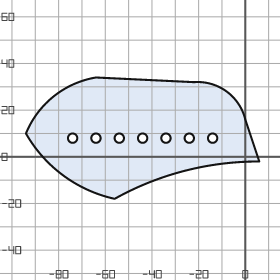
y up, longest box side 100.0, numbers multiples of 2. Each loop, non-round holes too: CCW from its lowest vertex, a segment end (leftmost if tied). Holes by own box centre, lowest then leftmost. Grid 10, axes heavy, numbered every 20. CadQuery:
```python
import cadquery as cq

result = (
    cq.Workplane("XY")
    .moveTo(-56.0, -18.0)
    .threePointArc((-26.0, -6.0), (6.0, -2.0))
    .lineTo(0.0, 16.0)
    .threePointArc((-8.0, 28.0), (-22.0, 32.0))
    .lineTo(-64.0, 34.0)
    .threePointArc((-82.0, 26.0), (-94.0, 10.0))
    .threePointArc((-78.0, -8.0), (-56.0, -18.0))
    .close()
    .moveTo(-74.0, 8.0)
    .circle(2.0)
    .moveTo(-64.0, 8.0)
    .circle(2.0)
    .moveTo(-54.0, 8.0)
    .circle(2.0)
    .moveTo(-44.0, 8.0)
    .circle(2.0)
    .moveTo(-34.0, 8.0)
    .circle(2.0)
    .moveTo(-24.0, 8.0)
    .circle(2.0)
    .moveTo(-14.0, 8.0)
    .circle(2.0)
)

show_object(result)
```